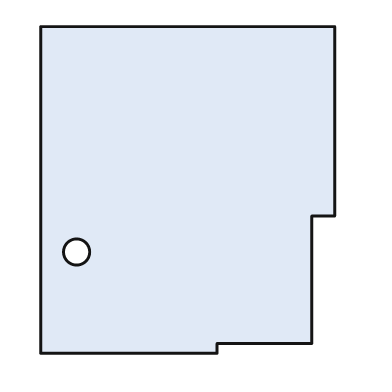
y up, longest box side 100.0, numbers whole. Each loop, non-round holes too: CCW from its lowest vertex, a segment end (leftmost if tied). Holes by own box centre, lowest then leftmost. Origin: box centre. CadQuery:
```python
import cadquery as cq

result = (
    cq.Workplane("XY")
    .moveTo(-45.0, -50.0)
    .lineTo(9.0, -50.0)
    .lineTo(9.0, -47.0)
    .lineTo(38.0, -47.0)
    .lineTo(38.0, -8.0)
    .lineTo(45.0, -8.0)
    .lineTo(45.0, 50.0)
    .lineTo(-45.0, 50.0)
    .close()
    .moveTo(-34.0, -19.0)
    .circle(4.0)
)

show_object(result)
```